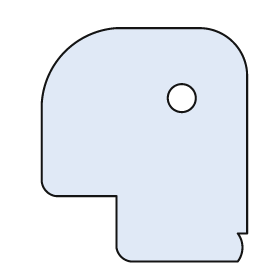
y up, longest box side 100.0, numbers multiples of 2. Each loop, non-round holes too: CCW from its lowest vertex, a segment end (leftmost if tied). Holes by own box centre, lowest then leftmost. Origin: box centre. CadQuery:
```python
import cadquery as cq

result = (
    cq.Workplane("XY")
    .moveTo(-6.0, -50.0)
    .lineTo(40.0, -50.0)
    .threePointArc((42.0, -44.0), (40.0, -38.0))
    .lineTo(44.0, -38.0)
    .lineTo(44.0, 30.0)
    .threePointArc((38.0, 44.0), (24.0, 50.0))
    .lineTo(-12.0, 50.0)
    .threePointArc((-34.0, 40.0), (-44.0, 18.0))
    .lineTo(-44.0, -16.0)
    .threePointArc((-42.0, -20.0), (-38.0, -22.0))
    .lineTo(-12.0, -22.0)
    .lineTo(-12.0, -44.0)
    .threePointArc((-10.0, -48.0), (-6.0, -50.0))
    .close()
    .moveTo(16.0, 20.0)
    .circle(6.0)
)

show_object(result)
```